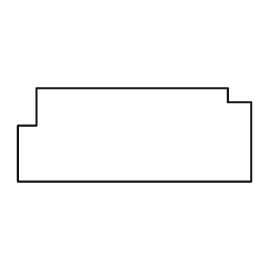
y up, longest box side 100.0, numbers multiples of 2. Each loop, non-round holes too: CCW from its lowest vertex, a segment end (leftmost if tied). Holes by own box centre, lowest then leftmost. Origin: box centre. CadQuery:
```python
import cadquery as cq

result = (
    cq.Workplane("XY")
    .moveTo(-50.0, -20.0)
    .lineTo(50.0, -20.0)
    .lineTo(50.0, 14.0)
    .lineTo(40.0, 14.0)
    .lineTo(40.0, 20.0)
    .lineTo(-42.0, 20.0)
    .lineTo(-42.0, 4.0)
    .lineTo(-50.0, 4.0)
    .close()
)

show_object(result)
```